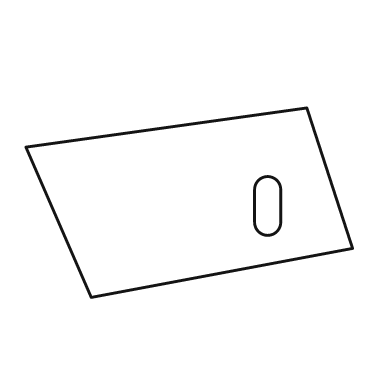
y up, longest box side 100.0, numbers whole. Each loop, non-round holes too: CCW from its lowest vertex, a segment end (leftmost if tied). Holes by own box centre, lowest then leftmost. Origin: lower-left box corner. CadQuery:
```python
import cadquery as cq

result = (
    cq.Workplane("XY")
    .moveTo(20.0, 0.0)
    .lineTo(100.0, 15.0)
    .lineTo(86.0, 58.0)
    .lineTo(0.0, 46.0)
    .close()
    .moveTo(70.0, 23.0)
    .threePointArc((74.0, 19.0), (78.0, 23.0))
    .lineTo(78.0, 33.0)
    .threePointArc((74.0, 37.0), (70.0, 33.0))
    .close()
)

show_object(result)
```